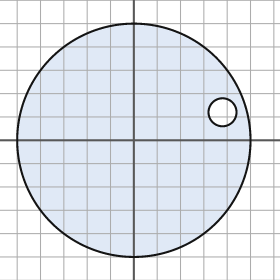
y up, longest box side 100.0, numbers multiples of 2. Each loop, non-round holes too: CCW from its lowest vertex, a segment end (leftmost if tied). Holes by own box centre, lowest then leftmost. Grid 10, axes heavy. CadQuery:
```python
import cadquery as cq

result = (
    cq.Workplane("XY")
    .moveTo(0.0, 0.0)
    .circle(50.0)
    .moveTo(38.0, 12.0)
    .circle(6.0)
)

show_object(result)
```